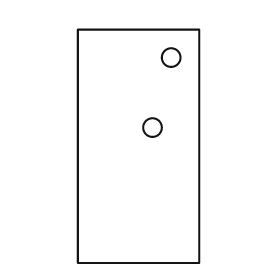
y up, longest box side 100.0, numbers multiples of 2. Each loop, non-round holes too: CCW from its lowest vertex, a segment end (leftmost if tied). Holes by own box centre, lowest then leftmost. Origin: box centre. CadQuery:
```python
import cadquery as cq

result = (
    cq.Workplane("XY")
    .moveTo(-26.0, -50.0)
    .lineTo(26.0, -50.0)
    .lineTo(26.0, 50.0)
    .lineTo(-26.0, 50.0)
    .close()
    .moveTo(6.0, 8.0)
    .circle(4.0)
    .moveTo(14.0, 38.0)
    .circle(4.0)
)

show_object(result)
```